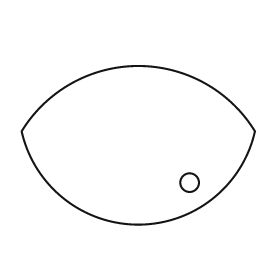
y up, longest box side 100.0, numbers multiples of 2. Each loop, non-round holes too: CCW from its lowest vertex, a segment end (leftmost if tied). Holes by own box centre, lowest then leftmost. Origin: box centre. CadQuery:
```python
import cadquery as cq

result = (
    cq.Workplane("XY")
    .moveTo(-50.0, 6.0)
    .threePointArc((0.0, -34.0), (50.0, 6.0))
    .threePointArc((0.0, 34.0), (-50.0, 6.0))
    .close()
    .moveTo(22.0, -16.0)
    .circle(4.0)
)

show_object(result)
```